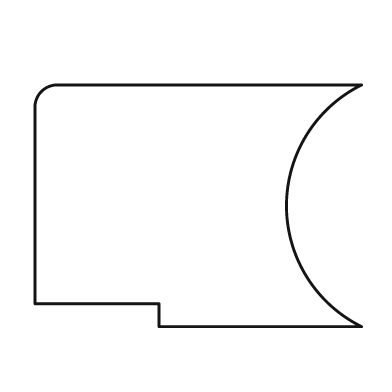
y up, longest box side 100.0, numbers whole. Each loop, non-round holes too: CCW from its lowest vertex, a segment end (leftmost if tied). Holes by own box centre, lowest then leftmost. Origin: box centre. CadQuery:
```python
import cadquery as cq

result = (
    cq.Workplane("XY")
    .moveTo(-12.0, -37.0)
    .lineTo(50.0, -37.0)
    .threePointArc((27.0, 0.0), (50.0, 37.0))
    .lineTo(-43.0, 37.0)
    .threePointArc((-48.0, 35.0), (-50.0, 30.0))
    .lineTo(-50.0, -30.0)
    .lineTo(-12.0, -30.0)
    .close()
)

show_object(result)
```